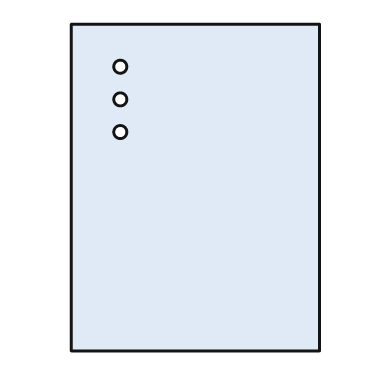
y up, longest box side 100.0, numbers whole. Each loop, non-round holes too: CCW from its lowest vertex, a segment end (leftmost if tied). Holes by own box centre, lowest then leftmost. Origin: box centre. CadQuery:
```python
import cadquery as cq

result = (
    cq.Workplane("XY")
    .moveTo(-38.0, -50.0)
    .lineTo(38.0, -50.0)
    .lineTo(38.0, 50.0)
    .lineTo(-38.0, 50.0)
    .close()
    .moveTo(-23.0, 17.0)
    .circle(2.0)
    .moveTo(-23.0, 27.0)
    .circle(2.0)
    .moveTo(-23.0, 37.0)
    .circle(2.0)
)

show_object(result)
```